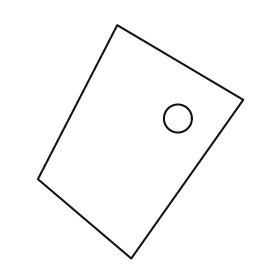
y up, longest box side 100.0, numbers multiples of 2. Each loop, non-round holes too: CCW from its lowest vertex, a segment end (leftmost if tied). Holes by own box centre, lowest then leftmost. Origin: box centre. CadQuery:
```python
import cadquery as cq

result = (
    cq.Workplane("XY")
    .moveTo(-4.0, -50.0)
    .lineTo(44.0, 18.0)
    .lineTo(-10.0, 50.0)
    .lineTo(-44.0, -16.0)
    .close()
    .moveTo(16.0, 10.0)
    .circle(6.0)
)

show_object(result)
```